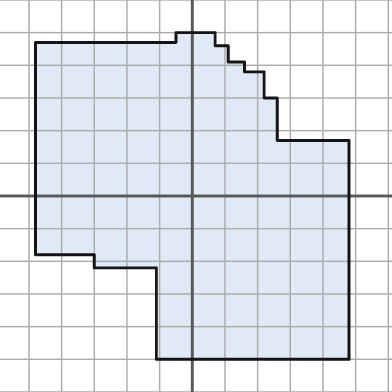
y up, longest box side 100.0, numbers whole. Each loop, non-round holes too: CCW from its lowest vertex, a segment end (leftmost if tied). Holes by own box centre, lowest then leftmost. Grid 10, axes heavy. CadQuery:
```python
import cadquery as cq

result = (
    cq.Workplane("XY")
    .moveTo(-11.0, -50.0)
    .lineTo(48.0, -50.0)
    .lineTo(48.0, 17.0)
    .lineTo(26.0, 17.0)
    .lineTo(26.0, 30.0)
    .lineTo(22.0, 30.0)
    .lineTo(22.0, 38.0)
    .lineTo(16.0, 38.0)
    .lineTo(16.0, 41.0)
    .lineTo(11.0, 41.0)
    .lineTo(11.0, 46.0)
    .lineTo(7.0, 46.0)
    .lineTo(7.0, 50.0)
    .lineTo(-5.0, 50.0)
    .lineTo(-5.0, 47.0)
    .lineTo(-48.0, 47.0)
    .lineTo(-48.0, -18.0)
    .lineTo(-30.0, -18.0)
    .lineTo(-30.0, -22.0)
    .lineTo(-11.0, -22.0)
    .close()
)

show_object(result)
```